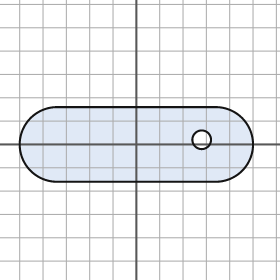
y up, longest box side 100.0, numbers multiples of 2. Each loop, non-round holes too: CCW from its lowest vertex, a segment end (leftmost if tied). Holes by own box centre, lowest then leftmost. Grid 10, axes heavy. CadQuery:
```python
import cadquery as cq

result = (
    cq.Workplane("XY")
    .moveTo(-34.0, -16.0)
    .lineTo(34.0, -16.0)
    .threePointArc((50.0, 0.0), (34.0, 16.0))
    .lineTo(-34.0, 16.0)
    .threePointArc((-50.0, 0.0), (-34.0, -16.0))
    .close()
    .moveTo(28.0, 2.0)
    .circle(4.0)
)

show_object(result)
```